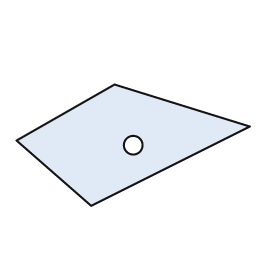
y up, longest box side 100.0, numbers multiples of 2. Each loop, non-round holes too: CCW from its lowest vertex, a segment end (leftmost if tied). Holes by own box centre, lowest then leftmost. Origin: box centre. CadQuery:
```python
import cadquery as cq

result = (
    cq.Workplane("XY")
    .moveTo(-18.0, -26.0)
    .lineTo(50.0, 8.0)
    .lineTo(-8.0, 26.0)
    .lineTo(-50.0, 2.0)
    .close()
    .moveTo(0.0, 0.0)
    .circle(4.0)
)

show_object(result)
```